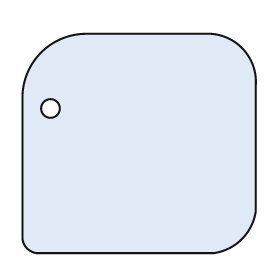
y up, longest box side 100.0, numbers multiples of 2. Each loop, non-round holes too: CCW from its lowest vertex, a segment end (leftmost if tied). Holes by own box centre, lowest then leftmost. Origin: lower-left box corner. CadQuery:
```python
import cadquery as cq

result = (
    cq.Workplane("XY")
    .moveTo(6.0, 0.0)
    .lineTo(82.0, 0.0)
    .threePointArc((94.0, 6.0), (100.0, 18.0))
    .lineTo(100.0, 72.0)
    .threePointArc((94.0, 88.0), (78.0, 94.0))
    .lineTo(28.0, 94.0)
    .threePointArc((8.0, 86.0), (0.0, 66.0))
    .lineTo(0.0, 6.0)
    .threePointArc((2.0, 2.0), (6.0, 0.0))
    .close()
    .moveTo(12.0, 62.0)
    .circle(4.0)
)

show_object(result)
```